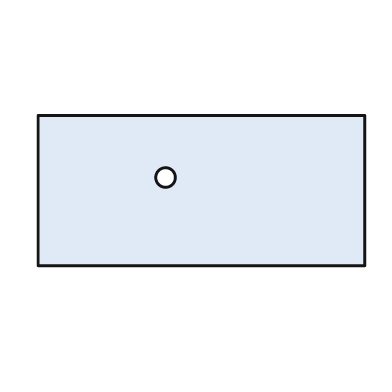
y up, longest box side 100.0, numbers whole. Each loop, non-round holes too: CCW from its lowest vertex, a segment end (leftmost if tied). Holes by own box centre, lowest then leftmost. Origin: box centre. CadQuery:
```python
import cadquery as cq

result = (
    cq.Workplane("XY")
    .moveTo(-50.0, -23.0)
    .lineTo(50.0, -23.0)
    .lineTo(50.0, 23.0)
    .lineTo(-50.0, 23.0)
    .close()
    .moveTo(-11.0, 4.0)
    .circle(3.0)
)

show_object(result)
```